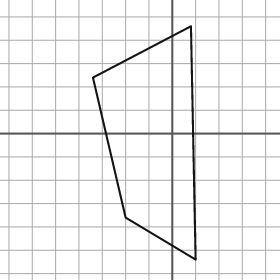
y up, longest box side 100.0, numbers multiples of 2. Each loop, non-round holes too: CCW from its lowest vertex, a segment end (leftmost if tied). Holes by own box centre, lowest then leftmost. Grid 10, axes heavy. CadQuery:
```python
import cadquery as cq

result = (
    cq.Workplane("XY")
    .moveTo(10.0, -54.0)
    .lineTo(8.0, 46.0)
    .lineTo(-34.0, 24.0)
    .lineTo(-20.0, -36.0)
    .close()
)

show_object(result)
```